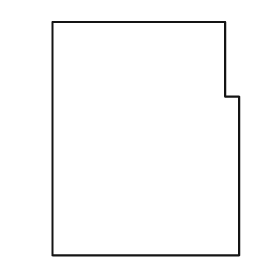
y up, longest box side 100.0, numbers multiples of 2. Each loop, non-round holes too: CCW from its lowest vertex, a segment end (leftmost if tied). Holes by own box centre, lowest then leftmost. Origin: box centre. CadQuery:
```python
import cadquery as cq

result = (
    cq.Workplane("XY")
    .moveTo(-40.0, -50.0)
    .lineTo(40.0, -50.0)
    .lineTo(40.0, 18.0)
    .lineTo(34.0, 18.0)
    .lineTo(34.0, 50.0)
    .lineTo(-40.0, 50.0)
    .close()
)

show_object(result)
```